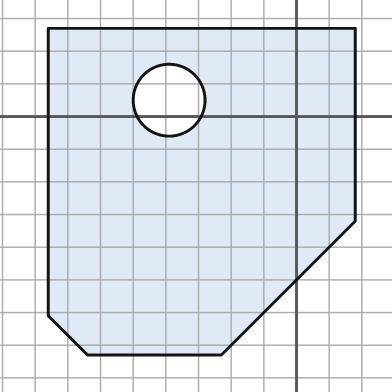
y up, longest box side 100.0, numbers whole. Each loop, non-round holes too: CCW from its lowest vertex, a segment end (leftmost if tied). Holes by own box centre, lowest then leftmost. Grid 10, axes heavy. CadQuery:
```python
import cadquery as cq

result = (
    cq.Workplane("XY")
    .moveTo(-64.0, -73.0)
    .lineTo(-23.0, -73.0)
    .lineTo(18.0, -32.0)
    .lineTo(18.0, 27.0)
    .lineTo(-76.0, 27.0)
    .lineTo(-76.0, -61.0)
    .close()
    .moveTo(-39.0, 5.0)
    .circle(11.0)
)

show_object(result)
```